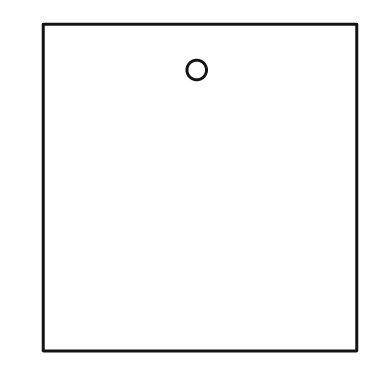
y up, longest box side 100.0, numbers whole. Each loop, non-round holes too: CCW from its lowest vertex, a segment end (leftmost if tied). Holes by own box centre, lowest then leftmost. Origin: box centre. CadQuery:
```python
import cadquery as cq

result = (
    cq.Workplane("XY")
    .moveTo(-48.0, -50.0)
    .lineTo(48.0, -50.0)
    .lineTo(48.0, 50.0)
    .lineTo(-48.0, 50.0)
    .close()
    .moveTo(-1.0, 36.0)
    .circle(3.0)
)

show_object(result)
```